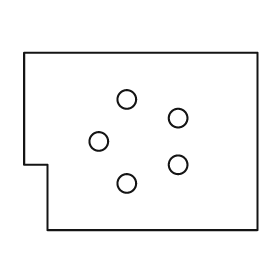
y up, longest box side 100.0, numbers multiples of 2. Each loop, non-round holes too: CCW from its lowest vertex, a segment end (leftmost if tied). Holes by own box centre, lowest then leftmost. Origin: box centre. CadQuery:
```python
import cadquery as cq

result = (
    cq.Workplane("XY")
    .moveTo(-40.0, -38.0)
    .lineTo(50.0, -38.0)
    .lineTo(50.0, 38.0)
    .lineTo(-50.0, 38.0)
    .lineTo(-50.0, -10.0)
    .lineTo(-40.0, -10.0)
    .close()
    .moveTo(-6.0, -18.0)
    .circle(4.0)
    .moveTo(16.0, -10.0)
    .circle(4.0)
    .moveTo(-18.0, 0.0)
    .circle(4.0)
    .moveTo(16.0, 10.0)
    .circle(4.0)
    .moveTo(-6.0, 18.0)
    .circle(4.0)
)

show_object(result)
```